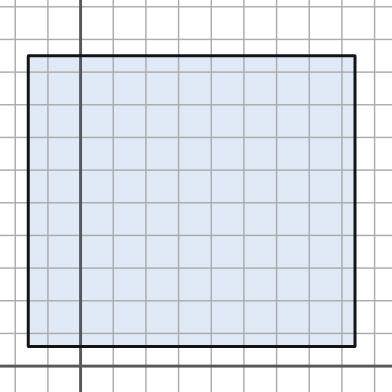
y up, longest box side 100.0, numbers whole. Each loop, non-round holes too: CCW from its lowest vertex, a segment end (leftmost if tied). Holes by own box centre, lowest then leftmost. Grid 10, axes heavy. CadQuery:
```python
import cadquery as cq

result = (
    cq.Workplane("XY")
    .moveTo(-16.0, 6.0)
    .lineTo(84.0, 6.0)
    .lineTo(84.0, 95.0)
    .lineTo(-16.0, 95.0)
    .close()
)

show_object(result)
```